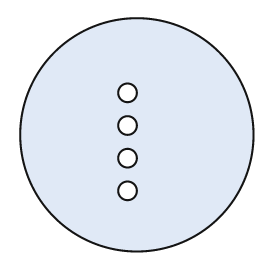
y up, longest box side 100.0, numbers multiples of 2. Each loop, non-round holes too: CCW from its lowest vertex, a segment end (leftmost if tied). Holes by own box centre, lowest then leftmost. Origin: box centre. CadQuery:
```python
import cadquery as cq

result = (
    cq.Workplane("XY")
    .moveTo(0.0, 0.0)
    .circle(50.0)
    .moveTo(-4.0, -24.0)
    .circle(4.0)
    .moveTo(-4.0, -10.0)
    .circle(4.0)
    .moveTo(-4.0, 4.0)
    .circle(4.0)
    .moveTo(-4.0, 18.0)
    .circle(4.0)
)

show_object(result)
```